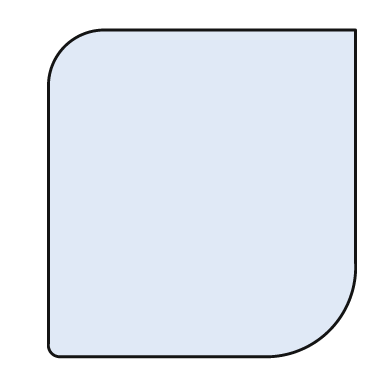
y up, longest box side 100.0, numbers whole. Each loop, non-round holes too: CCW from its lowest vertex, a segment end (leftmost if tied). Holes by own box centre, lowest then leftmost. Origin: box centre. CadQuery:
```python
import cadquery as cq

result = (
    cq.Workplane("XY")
    .moveTo(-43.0, -50.0)
    .lineTo(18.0, -50.0)
    .threePointArc((39.0, -42.0), (47.0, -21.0))
    .lineTo(47.0, 50.0)
    .lineTo(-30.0, 50.0)
    .threePointArc((-42.0, 45.0), (-47.0, 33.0))
    .lineTo(-47.0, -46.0)
    .threePointArc((-46.0, -49.0), (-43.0, -50.0))
    .close()
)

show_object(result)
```